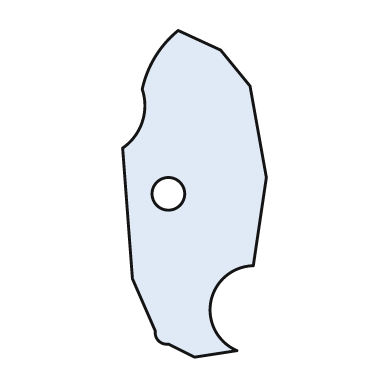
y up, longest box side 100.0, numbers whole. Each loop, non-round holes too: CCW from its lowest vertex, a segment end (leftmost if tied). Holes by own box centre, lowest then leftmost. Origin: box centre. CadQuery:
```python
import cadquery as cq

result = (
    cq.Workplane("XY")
    .moveTo(0.0, -50.0)
    .lineTo(13.0, -48.0)
    .threePointArc((5.0, -33.0), (18.0, -22.0))
    .lineTo(22.0, 5.0)
    .lineTo(17.0, 33.0)
    .lineTo(8.0, 44.0)
    .lineTo(-5.0, 50.0)
    .threePointArc((-12.0, 42.0), (-16.0, 32.0))
    .threePointArc((-16.0, 22.0), (-22.0, 14.0))
    .lineTo(-19.0, -26.0)
    .lineTo(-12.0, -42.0)
    .threePointArc((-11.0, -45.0), (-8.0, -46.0))
    .close()
    .moveTo(-8.0, 0.0)
    .circle(5.0)
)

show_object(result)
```